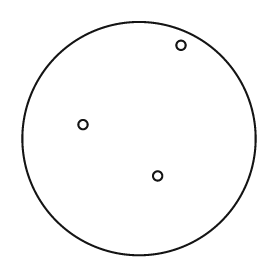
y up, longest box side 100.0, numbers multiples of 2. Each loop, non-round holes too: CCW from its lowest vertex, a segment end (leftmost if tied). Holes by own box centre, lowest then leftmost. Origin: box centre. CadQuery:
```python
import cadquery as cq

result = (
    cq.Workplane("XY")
    .moveTo(0.0, 0.0)
    .circle(50.0)
    .moveTo(8.0, -16.0)
    .circle(2.0)
    .moveTo(-24.0, 6.0)
    .circle(2.0)
    .moveTo(18.0, 40.0)
    .circle(2.0)
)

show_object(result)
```